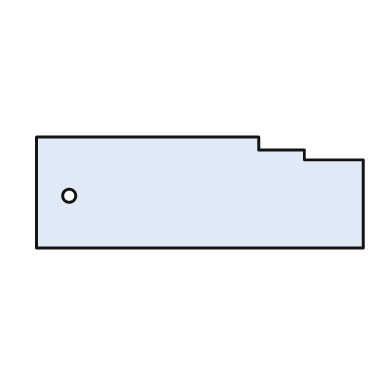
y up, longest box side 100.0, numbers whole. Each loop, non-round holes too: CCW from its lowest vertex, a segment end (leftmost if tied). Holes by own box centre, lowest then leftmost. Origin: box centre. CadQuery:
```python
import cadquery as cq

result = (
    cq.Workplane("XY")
    .moveTo(-50.0, -17.0)
    .lineTo(50.0, -17.0)
    .lineTo(50.0, 10.0)
    .lineTo(32.0, 10.0)
    .lineTo(32.0, 13.0)
    .lineTo(18.0, 13.0)
    .lineTo(18.0, 17.0)
    .lineTo(-50.0, 17.0)
    .close()
    .moveTo(-40.0, -1.0)
    .circle(2.0)
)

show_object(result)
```